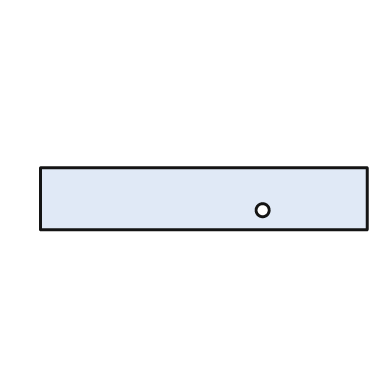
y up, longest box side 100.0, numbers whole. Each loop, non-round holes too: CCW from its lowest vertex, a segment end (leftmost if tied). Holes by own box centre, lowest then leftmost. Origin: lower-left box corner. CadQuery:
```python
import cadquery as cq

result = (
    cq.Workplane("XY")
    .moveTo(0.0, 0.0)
    .lineTo(100.0, 0.0)
    .lineTo(100.0, 19.0)
    .lineTo(0.0, 19.0)
    .close()
    .moveTo(68.0, 6.0)
    .circle(2.0)
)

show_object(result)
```